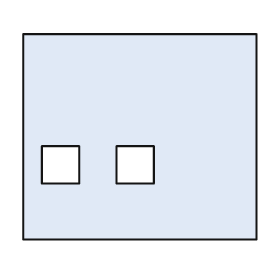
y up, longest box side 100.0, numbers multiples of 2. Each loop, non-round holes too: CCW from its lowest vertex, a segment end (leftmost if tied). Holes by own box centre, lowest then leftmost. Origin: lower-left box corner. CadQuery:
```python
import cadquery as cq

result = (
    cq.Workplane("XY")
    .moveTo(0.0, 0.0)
    .lineTo(100.0, 0.0)
    .lineTo(100.0, 88.0)
    .lineTo(0.0, 88.0)
    .close()
    .moveTo(8.0, 24.0)
    .lineTo(24.0, 24.0)
    .lineTo(24.0, 40.0)
    .lineTo(8.0, 40.0)
    .close()
    .moveTo(40.0, 24.0)
    .lineTo(56.0, 24.0)
    .lineTo(56.0, 40.0)
    .lineTo(40.0, 40.0)
    .close()
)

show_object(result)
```